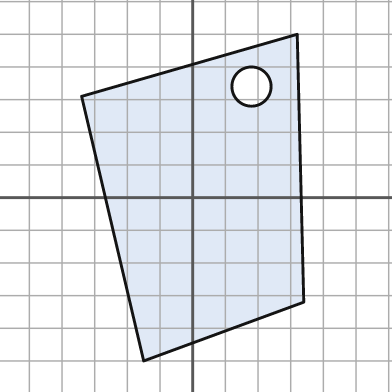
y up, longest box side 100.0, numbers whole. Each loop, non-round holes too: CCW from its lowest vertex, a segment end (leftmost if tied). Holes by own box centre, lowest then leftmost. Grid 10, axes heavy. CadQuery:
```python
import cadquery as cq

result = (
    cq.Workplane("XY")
    .moveTo(-15.0, -50.0)
    .lineTo(34.0, -32.0)
    .lineTo(32.0, 50.0)
    .lineTo(-34.0, 31.0)
    .close()
    .moveTo(18.0, 34.0)
    .circle(6.0)
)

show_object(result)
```